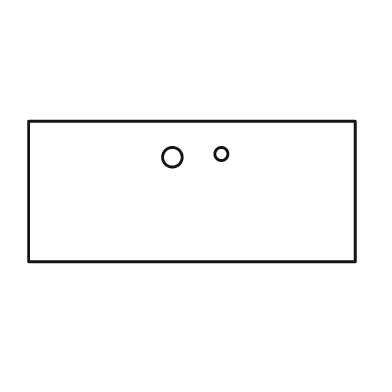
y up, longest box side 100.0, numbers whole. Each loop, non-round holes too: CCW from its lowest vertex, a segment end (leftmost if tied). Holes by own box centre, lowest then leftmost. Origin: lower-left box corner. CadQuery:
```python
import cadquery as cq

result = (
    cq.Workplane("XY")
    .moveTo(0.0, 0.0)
    .lineTo(100.0, 0.0)
    .lineTo(100.0, 43.0)
    .lineTo(0.0, 43.0)
    .close()
    .moveTo(44.0, 32.0)
    .circle(3.0)
    .moveTo(59.0, 33.0)
    .circle(2.0)
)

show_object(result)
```